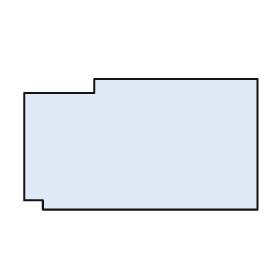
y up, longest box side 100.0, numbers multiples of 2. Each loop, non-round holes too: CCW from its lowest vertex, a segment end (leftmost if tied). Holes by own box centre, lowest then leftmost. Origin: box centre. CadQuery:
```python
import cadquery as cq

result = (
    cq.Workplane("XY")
    .moveTo(-42.0, -28.0)
    .lineTo(50.0, -28.0)
    .lineTo(50.0, 28.0)
    .lineTo(-20.0, 28.0)
    .lineTo(-20.0, 22.0)
    .lineTo(-50.0, 22.0)
    .lineTo(-50.0, -24.0)
    .lineTo(-42.0, -24.0)
    .close()
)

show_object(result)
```